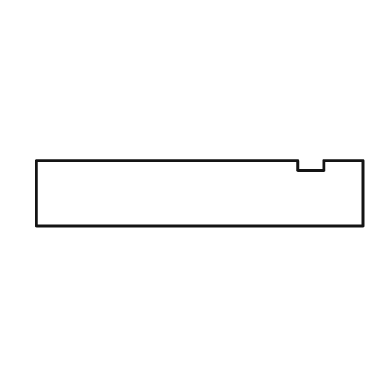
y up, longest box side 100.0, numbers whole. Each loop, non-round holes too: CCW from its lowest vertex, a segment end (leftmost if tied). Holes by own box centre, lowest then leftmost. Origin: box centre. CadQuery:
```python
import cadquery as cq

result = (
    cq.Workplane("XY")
    .moveTo(-50.0, -10.0)
    .lineTo(50.0, -10.0)
    .lineTo(50.0, 10.0)
    .lineTo(38.0, 10.0)
    .lineTo(38.0, 7.0)
    .lineTo(30.0, 7.0)
    .lineTo(30.0, 10.0)
    .lineTo(-50.0, 10.0)
    .close()
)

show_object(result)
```